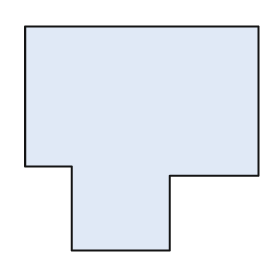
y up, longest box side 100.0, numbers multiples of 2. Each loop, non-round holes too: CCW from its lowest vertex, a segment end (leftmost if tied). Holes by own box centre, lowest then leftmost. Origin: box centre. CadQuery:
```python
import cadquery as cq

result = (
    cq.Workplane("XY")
    .moveTo(-30.0, -48.0)
    .lineTo(12.0, -48.0)
    .lineTo(12.0, -16.0)
    .lineTo(50.0, -16.0)
    .lineTo(50.0, 48.0)
    .lineTo(-50.0, 48.0)
    .lineTo(-50.0, -12.0)
    .lineTo(-30.0, -12.0)
    .close()
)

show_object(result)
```